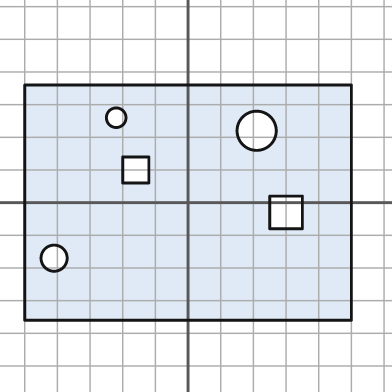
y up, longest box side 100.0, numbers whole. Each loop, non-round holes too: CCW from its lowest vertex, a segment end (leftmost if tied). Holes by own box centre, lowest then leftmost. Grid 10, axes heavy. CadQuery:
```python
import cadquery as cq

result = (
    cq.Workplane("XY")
    .moveTo(-50.0, -36.0)
    .lineTo(50.0, -36.0)
    .lineTo(50.0, 36.0)
    .lineTo(-50.0, 36.0)
    .close()
    .moveTo(-41.0, -17.0)
    .circle(4.0)
    .moveTo(25.0, -8.0)
    .lineTo(35.0, -8.0)
    .lineTo(35.0, 2.0)
    .lineTo(25.0, 2.0)
    .close()
    .moveTo(-20.0, 6.0)
    .lineTo(-12.0, 6.0)
    .lineTo(-12.0, 14.0)
    .lineTo(-20.0, 14.0)
    .close()
    .moveTo(21.0, 22.0)
    .circle(6.0)
    .moveTo(-22.0, 26.0)
    .circle(3.0)
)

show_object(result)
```